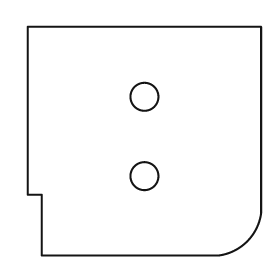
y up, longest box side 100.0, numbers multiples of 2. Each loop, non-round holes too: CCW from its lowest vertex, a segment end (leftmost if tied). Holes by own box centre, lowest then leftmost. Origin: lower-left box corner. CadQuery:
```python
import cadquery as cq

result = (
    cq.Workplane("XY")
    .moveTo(6.0, 0.0)
    .lineTo(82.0, 0.0)
    .threePointArc((94.0, 6.0), (100.0, 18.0))
    .lineTo(100.0, 98.0)
    .lineTo(0.0, 98.0)
    .lineTo(0.0, 26.0)
    .lineTo(6.0, 26.0)
    .close()
    .moveTo(50.0, 34.0)
    .circle(6.0)
    .moveTo(50.0, 68.0)
    .circle(6.0)
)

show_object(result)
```